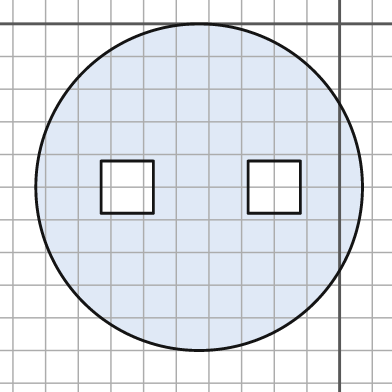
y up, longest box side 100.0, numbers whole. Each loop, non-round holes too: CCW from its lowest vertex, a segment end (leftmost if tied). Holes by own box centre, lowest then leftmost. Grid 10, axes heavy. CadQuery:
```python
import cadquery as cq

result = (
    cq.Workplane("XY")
    .moveTo(-43.0, -50.0)
    .circle(50.0)
    .moveTo(-73.0, -58.0)
    .lineTo(-57.0, -58.0)
    .lineTo(-57.0, -42.0)
    .lineTo(-73.0, -42.0)
    .close()
    .moveTo(-28.0, -58.0)
    .lineTo(-12.0, -58.0)
    .lineTo(-12.0, -42.0)
    .lineTo(-28.0, -42.0)
    .close()
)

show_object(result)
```